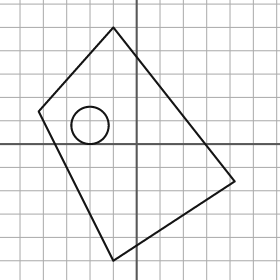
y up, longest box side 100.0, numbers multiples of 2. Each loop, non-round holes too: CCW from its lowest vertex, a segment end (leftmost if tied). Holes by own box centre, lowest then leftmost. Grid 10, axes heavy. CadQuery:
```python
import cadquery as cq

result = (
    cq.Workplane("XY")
    .moveTo(-10.0, -50.0)
    .lineTo(42.0, -16.0)
    .lineTo(-10.0, 50.0)
    .lineTo(-42.0, 14.0)
    .close()
    .moveTo(-20.0, 8.0)
    .circle(8.0)
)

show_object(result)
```